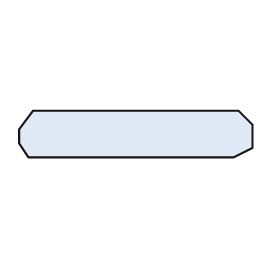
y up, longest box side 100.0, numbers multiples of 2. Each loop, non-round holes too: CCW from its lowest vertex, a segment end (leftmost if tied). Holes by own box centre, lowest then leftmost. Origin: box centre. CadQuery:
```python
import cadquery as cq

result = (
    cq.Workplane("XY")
    .moveTo(-46.0, -10.0)
    .lineTo(42.0, -10.0)
    .lineTo(50.0, -6.0)
    .lineTo(50.0, 4.0)
    .lineTo(44.0, 10.0)
    .lineTo(-44.0, 10.0)
    .lineTo(-50.0, 2.0)
    .lineTo(-50.0, -4.0)
    .close()
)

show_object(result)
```